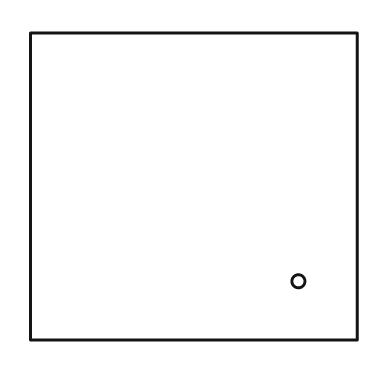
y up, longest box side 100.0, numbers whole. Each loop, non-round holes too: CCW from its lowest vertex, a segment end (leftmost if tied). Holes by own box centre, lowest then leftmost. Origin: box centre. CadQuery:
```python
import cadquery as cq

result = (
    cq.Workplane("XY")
    .moveTo(-50.0, -47.0)
    .lineTo(50.0, -47.0)
    .lineTo(50.0, 47.0)
    .lineTo(-50.0, 47.0)
    .close()
    .moveTo(32.0, -29.0)
    .circle(2.0)
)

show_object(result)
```